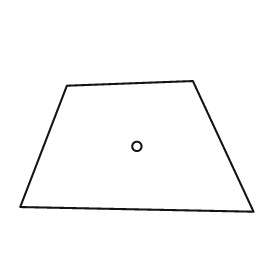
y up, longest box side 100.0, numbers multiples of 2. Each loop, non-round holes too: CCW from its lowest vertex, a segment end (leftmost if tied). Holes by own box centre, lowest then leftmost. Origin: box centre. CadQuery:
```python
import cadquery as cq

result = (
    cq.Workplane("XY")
    .moveTo(50.0, -28.0)
    .lineTo(24.0, 28.0)
    .lineTo(-30.0, 26.0)
    .lineTo(-50.0, -26.0)
    .close()
    .moveTo(0.0, 0.0)
    .circle(2.0)
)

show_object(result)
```